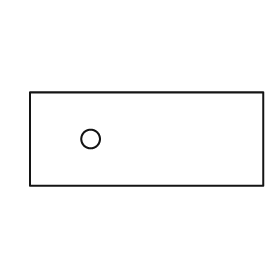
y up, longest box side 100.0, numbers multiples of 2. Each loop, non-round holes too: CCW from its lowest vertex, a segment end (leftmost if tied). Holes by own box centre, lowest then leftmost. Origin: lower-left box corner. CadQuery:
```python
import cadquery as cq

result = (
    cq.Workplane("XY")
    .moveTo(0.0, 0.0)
    .lineTo(100.0, 0.0)
    .lineTo(100.0, 40.0)
    .lineTo(0.0, 40.0)
    .close()
    .moveTo(26.0, 20.0)
    .circle(4.0)
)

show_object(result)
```